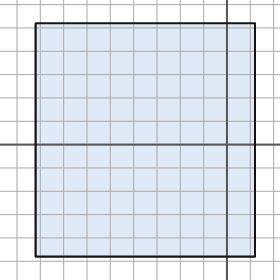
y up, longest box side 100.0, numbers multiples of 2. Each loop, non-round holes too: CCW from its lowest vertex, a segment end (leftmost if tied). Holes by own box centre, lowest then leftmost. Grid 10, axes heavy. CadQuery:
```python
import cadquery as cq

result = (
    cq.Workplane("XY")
    .moveTo(-82.0, -48.0)
    .lineTo(12.0, -48.0)
    .lineTo(12.0, 52.0)
    .lineTo(-82.0, 52.0)
    .close()
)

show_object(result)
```